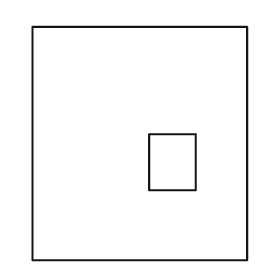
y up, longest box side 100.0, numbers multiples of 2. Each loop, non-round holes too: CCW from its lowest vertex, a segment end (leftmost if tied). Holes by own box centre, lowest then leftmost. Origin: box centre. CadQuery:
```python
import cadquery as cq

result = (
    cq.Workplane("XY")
    .moveTo(-46.0, -50.0)
    .lineTo(46.0, -50.0)
    .lineTo(46.0, 50.0)
    .lineTo(-46.0, 50.0)
    .close()
    .moveTo(4.0, -20.0)
    .lineTo(24.0, -20.0)
    .lineTo(24.0, 4.0)
    .lineTo(4.0, 4.0)
    .close()
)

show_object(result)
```